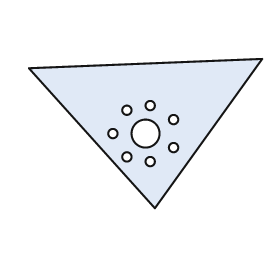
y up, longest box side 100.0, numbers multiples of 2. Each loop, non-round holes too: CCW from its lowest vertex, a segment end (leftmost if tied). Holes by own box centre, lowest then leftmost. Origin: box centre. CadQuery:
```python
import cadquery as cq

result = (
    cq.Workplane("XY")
    .moveTo(4.0, -32.0)
    .lineTo(50.0, 32.0)
    .lineTo(-50.0, 28.0)
    .close()
    .moveTo(2.0, -12.0)
    .circle(2.0)
    .moveTo(-8.0, -10.0)
    .circle(2.0)
    .moveTo(12.0, -6.0)
    .circle(2.0)
    .moveTo(-14.0, 0.0)
    .circle(2.0)
    .moveTo(0.0, 0.0)
    .circle(6.0)
    .moveTo(12.0, 6.0)
    .circle(2.0)
    .moveTo(-8.0, 10.0)
    .circle(2.0)
    .moveTo(2.0, 12.0)
    .circle(2.0)
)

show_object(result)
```